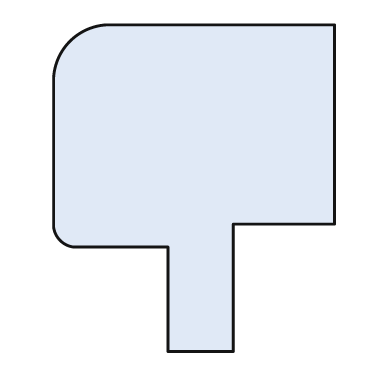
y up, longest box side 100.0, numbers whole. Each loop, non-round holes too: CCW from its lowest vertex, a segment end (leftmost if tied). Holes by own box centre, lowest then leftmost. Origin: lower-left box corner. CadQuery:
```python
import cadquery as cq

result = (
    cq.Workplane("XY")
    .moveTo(35.0, 0.0)
    .lineTo(55.0, 0.0)
    .lineTo(55.0, 39.0)
    .lineTo(86.0, 39.0)
    .lineTo(86.0, 100.0)
    .lineTo(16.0, 100.0)
    .threePointArc((5.0, 95.0), (0.0, 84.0))
    .lineTo(0.0, 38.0)
    .threePointArc((2.0, 34.0), (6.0, 32.0))
    .lineTo(35.0, 32.0)
    .close()
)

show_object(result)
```